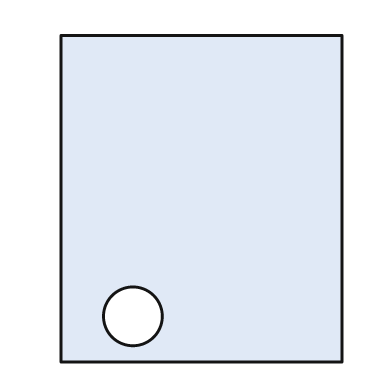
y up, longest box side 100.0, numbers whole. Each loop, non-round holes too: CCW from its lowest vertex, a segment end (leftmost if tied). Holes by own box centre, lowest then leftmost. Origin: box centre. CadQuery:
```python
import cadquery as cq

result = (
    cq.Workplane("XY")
    .moveTo(-43.0, -50.0)
    .lineTo(43.0, -50.0)
    .lineTo(43.0, 50.0)
    .lineTo(-43.0, 50.0)
    .close()
    .moveTo(-21.0, -36.0)
    .circle(9.0)
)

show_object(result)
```